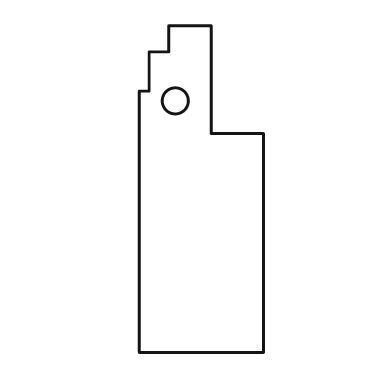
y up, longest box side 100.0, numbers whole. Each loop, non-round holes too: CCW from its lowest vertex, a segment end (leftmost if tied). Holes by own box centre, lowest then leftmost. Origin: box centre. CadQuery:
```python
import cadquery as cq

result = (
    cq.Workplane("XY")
    .moveTo(-19.0, -50.0)
    .lineTo(19.0, -50.0)
    .lineTo(19.0, 17.0)
    .lineTo(3.0, 17.0)
    .lineTo(3.0, 50.0)
    .lineTo(-10.0, 50.0)
    .lineTo(-10.0, 42.0)
    .lineTo(-16.0, 42.0)
    .lineTo(-16.0, 30.0)
    .lineTo(-19.0, 30.0)
    .close()
    .moveTo(-8.0, 27.0)
    .circle(4.0)
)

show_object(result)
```